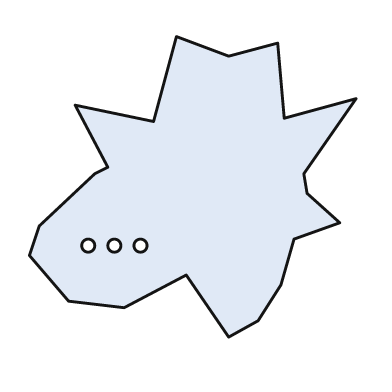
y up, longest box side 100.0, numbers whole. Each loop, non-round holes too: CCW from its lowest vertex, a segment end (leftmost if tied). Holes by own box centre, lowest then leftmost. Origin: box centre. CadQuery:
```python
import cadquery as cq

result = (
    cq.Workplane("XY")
    .moveTo(11.0, -46.0)
    .lineTo(20.0, -41.0)
    .lineTo(27.0, -30.0)
    .lineTo(31.0, -16.0)
    .lineTo(45.0, -11.0)
    .lineTo(35.0, -2.0)
    .lineTo(34.0, 4.0)
    .lineTo(50.0, 27.0)
    .lineTo(28.0, 21.0)
    .lineTo(26.0, 44.0)
    .lineTo(11.0, 40.0)
    .lineTo(-5.0, 46.0)
    .lineTo(-12.0, 20.0)
    .lineTo(-36.0, 25.0)
    .lineTo(-26.0, 6.0)
    .lineTo(-30.0, 4.0)
    .lineTo(-47.0, -12.0)
    .lineTo(-50.0, -21.0)
    .lineTo(-38.0, -35.0)
    .lineTo(-21.0, -37.0)
    .lineTo(-2.0, -27.0)
    .close()
    .moveTo(-32.0, -18.0)
    .circle(2.0)
    .moveTo(-24.0, -18.0)
    .circle(2.0)
    .moveTo(-16.0, -18.0)
    .circle(2.0)
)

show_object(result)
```